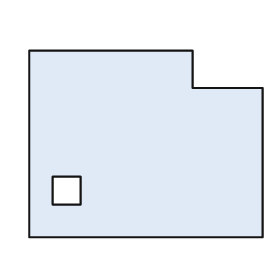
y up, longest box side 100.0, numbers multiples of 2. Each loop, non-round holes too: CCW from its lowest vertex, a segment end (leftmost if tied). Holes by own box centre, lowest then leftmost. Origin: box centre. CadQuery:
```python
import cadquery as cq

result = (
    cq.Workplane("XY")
    .moveTo(-50.0, -40.0)
    .lineTo(50.0, -40.0)
    .lineTo(50.0, 24.0)
    .lineTo(20.0, 24.0)
    .lineTo(20.0, 40.0)
    .lineTo(-50.0, 40.0)
    .close()
    .moveTo(-40.0, -26.0)
    .lineTo(-28.0, -26.0)
    .lineTo(-28.0, -14.0)
    .lineTo(-40.0, -14.0)
    .close()
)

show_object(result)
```